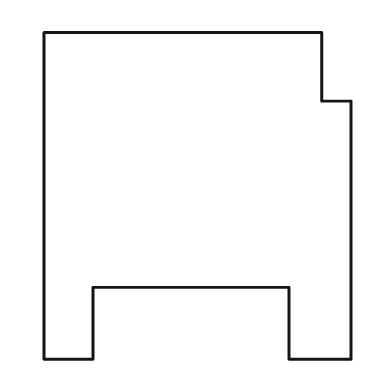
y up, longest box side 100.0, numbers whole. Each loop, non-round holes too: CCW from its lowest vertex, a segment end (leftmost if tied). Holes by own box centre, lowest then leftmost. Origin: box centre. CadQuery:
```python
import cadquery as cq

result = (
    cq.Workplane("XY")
    .moveTo(-47.0, -50.0)
    .lineTo(-32.0, -50.0)
    .lineTo(-32.0, -28.0)
    .lineTo(28.0, -28.0)
    .lineTo(28.0, -50.0)
    .lineTo(47.0, -50.0)
    .lineTo(47.0, 29.0)
    .lineTo(38.0, 29.0)
    .lineTo(38.0, 50.0)
    .lineTo(-47.0, 50.0)
    .close()
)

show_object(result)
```